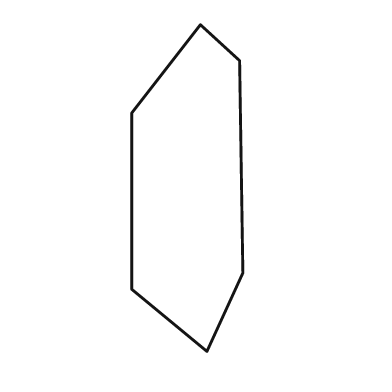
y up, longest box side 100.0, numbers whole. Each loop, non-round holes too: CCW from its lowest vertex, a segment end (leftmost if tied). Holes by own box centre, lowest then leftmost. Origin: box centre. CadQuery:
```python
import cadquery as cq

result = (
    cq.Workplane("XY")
    .moveTo(6.0, -50.0)
    .lineTo(17.0, -26.0)
    .lineTo(16.0, 39.0)
    .lineTo(4.0, 50.0)
    .lineTo(-17.0, 23.0)
    .lineTo(-17.0, -31.0)
    .close()
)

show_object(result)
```